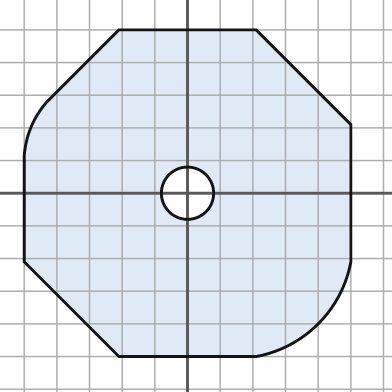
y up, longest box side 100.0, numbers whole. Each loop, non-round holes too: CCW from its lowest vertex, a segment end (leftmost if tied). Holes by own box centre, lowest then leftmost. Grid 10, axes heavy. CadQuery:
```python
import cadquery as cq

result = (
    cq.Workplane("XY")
    .moveTo(-21.0, -50.0)
    .lineTo(21.0, -50.0)
    .threePointArc((40.0, -40.0), (50.0, -21.0))
    .lineTo(50.0, 21.0)
    .lineTo(21.0, 50.0)
    .lineTo(-21.0, 50.0)
    .lineTo(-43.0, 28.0)
    .threePointArc((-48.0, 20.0), (-50.0, 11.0))
    .lineTo(-50.0, -21.0)
    .close()
    .moveTo(0.0, 0.0)
    .circle(8.0)
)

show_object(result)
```